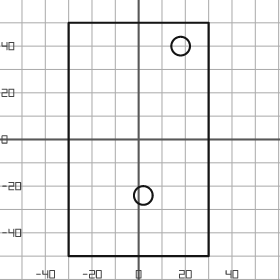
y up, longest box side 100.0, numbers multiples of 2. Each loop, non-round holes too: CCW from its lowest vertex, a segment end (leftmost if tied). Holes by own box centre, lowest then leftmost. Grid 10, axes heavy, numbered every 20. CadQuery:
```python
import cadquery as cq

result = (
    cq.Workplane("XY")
    .moveTo(-30.0, -50.0)
    .lineTo(30.0, -50.0)
    .lineTo(30.0, 50.0)
    .lineTo(-30.0, 50.0)
    .close()
    .moveTo(2.0, -24.0)
    .circle(4.0)
    .moveTo(18.0, 40.0)
    .circle(4.0)
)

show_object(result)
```